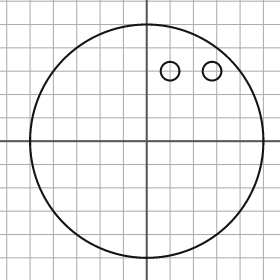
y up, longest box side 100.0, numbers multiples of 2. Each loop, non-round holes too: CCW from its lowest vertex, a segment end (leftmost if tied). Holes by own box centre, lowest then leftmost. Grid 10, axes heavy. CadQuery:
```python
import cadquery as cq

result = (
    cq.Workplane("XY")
    .moveTo(0.0, 0.0)
    .circle(50.0)
    .moveTo(10.0, 30.0)
    .circle(4.0)
    .moveTo(28.0, 30.0)
    .circle(4.0)
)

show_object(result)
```